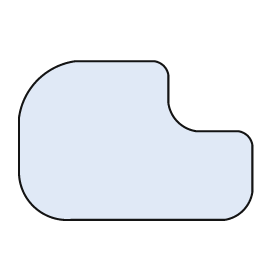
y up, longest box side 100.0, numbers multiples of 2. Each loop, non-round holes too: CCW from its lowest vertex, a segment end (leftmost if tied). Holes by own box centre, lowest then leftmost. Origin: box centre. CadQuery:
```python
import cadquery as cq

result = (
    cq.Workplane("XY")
    .moveTo(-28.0, -34.0)
    .lineTo(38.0, -34.0)
    .threePointArc((46.0, -30.0), (50.0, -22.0))
    .lineTo(50.0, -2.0)
    .threePointArc((48.0, 2.0), (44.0, 4.0))
    .lineTo(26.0, 4.0)
    .threePointArc((18.0, 8.0), (14.0, 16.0))
    .lineTo(14.0, 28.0)
    .threePointArc((12.0, 32.0), (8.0, 34.0))
    .lineTo(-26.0, 34.0)
    .threePointArc((-42.0, 26.0), (-50.0, 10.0))
    .lineTo(-50.0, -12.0)
    .threePointArc((-44.0, -28.0), (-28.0, -34.0))
    .close()
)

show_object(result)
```